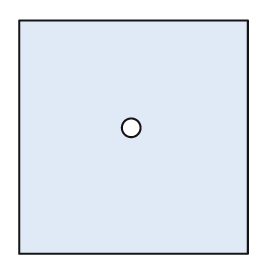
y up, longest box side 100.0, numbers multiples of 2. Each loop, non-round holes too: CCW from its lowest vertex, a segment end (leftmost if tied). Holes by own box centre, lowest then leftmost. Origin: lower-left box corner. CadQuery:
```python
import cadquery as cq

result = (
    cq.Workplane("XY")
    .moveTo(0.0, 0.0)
    .lineTo(98.0, 0.0)
    .lineTo(98.0, 100.0)
    .lineTo(0.0, 100.0)
    .close()
    .moveTo(48.0, 54.0)
    .circle(4.0)
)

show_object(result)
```